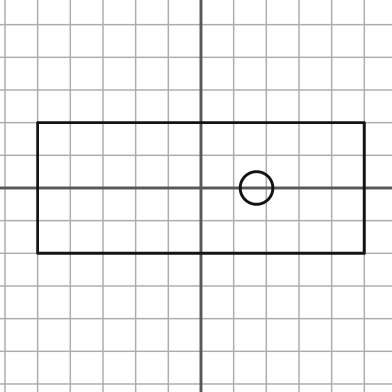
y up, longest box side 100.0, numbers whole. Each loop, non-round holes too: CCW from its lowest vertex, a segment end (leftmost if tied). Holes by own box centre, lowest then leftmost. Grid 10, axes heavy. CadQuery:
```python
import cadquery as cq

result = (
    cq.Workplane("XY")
    .moveTo(-50.0, -20.0)
    .lineTo(50.0, -20.0)
    .lineTo(50.0, 20.0)
    .lineTo(-50.0, 20.0)
    .close()
    .moveTo(17.0, 0.0)
    .circle(5.0)
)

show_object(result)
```